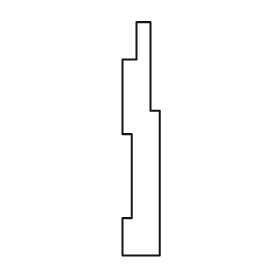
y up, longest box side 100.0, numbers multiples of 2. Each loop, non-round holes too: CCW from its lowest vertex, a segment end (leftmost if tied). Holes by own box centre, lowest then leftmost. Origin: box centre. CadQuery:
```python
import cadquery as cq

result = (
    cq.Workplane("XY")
    .moveTo(-8.0, -50.0)
    .lineTo(8.0, -50.0)
    .lineTo(8.0, 12.0)
    .lineTo(4.0, 12.0)
    .lineTo(4.0, 50.0)
    .lineTo(-2.0, 50.0)
    .lineTo(-2.0, 34.0)
    .lineTo(-8.0, 34.0)
    .lineTo(-8.0, 2.0)
    .lineTo(-4.0, 2.0)
    .lineTo(-4.0, -34.0)
    .lineTo(-8.0, -34.0)
    .close()
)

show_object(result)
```